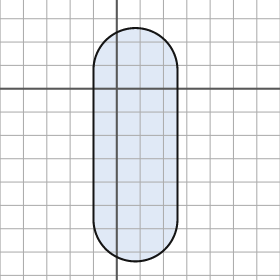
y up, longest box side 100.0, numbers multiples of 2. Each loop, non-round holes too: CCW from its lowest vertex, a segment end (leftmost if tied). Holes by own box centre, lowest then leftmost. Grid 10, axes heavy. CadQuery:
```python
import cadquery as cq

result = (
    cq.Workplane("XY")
    .moveTo(-10.0, -56.0)
    .threePointArc((8.0, -74.0), (26.0, -56.0))
    .lineTo(26.0, 8.0)
    .threePointArc((8.0, 26.0), (-10.0, 8.0))
    .close()
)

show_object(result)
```